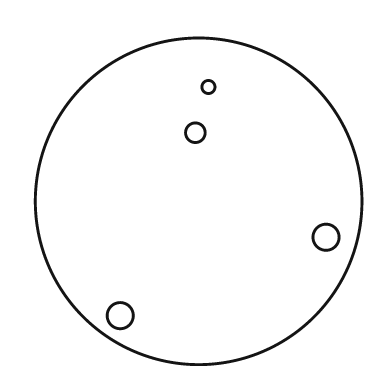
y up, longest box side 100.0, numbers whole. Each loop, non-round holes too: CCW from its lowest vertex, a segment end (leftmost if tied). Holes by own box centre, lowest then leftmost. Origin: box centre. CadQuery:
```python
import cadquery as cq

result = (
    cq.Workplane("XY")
    .moveTo(0.0, 0.0)
    .circle(50.0)
    .moveTo(-24.0, -35.0)
    .circle(4.0)
    .moveTo(39.0, -11.0)
    .circle(4.0)
    .moveTo(-1.0, 21.0)
    .circle(3.0)
    .moveTo(3.0, 35.0)
    .circle(2.0)
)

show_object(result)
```